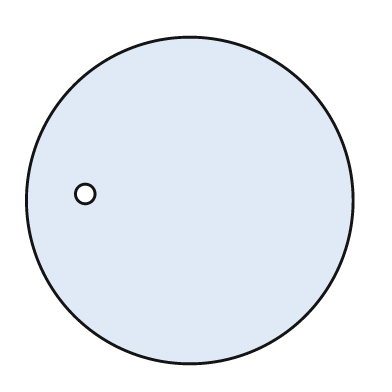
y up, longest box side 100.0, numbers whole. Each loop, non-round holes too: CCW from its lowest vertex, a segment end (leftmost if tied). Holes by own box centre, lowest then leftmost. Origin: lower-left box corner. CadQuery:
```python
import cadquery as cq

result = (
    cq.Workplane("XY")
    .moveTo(50.0, 50.0)
    .circle(50.0)
    .moveTo(18.0, 52.0)
    .circle(3.0)
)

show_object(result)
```